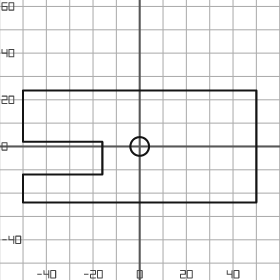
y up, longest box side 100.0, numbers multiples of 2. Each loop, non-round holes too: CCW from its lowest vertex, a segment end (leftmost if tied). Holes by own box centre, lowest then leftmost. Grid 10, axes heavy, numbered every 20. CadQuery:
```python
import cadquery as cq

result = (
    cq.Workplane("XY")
    .moveTo(-50.0, -24.0)
    .lineTo(50.0, -24.0)
    .lineTo(50.0, 24.0)
    .lineTo(-50.0, 24.0)
    .lineTo(-50.0, 2.0)
    .lineTo(-16.0, 2.0)
    .lineTo(-16.0, -12.0)
    .lineTo(-50.0, -12.0)
    .close()
    .moveTo(0.0, 0.0)
    .circle(4.0)
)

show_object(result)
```